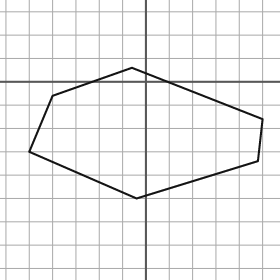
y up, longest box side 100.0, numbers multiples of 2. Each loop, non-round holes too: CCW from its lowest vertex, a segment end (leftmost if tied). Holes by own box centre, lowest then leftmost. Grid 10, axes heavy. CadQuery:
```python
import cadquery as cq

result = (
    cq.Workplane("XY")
    .moveTo(-4.0, -50.0)
    .lineTo(48.0, -34.0)
    .lineTo(50.0, -16.0)
    .lineTo(-6.0, 6.0)
    .lineTo(-40.0, -6.0)
    .lineTo(-50.0, -30.0)
    .close()
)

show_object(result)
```